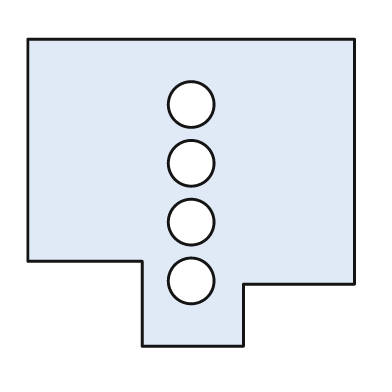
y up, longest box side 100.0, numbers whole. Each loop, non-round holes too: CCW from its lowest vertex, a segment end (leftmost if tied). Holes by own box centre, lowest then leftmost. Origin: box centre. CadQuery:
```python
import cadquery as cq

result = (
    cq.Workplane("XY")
    .moveTo(-15.0, -47.0)
    .lineTo(16.0, -47.0)
    .lineTo(16.0, -28.0)
    .lineTo(50.0, -28.0)
    .lineTo(50.0, 47.0)
    .lineTo(-50.0, 47.0)
    .lineTo(-50.0, -21.0)
    .lineTo(-15.0, -21.0)
    .close()
    .moveTo(0.0, -27.0)
    .circle(7.0)
    .moveTo(0.0, -9.0)
    .circle(7.0)
    .moveTo(0.0, 9.0)
    .circle(7.0)
    .moveTo(0.0, 27.0)
    .circle(7.0)
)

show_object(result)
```